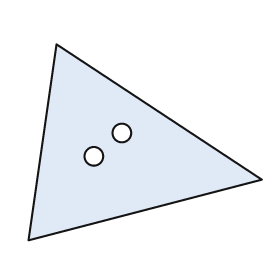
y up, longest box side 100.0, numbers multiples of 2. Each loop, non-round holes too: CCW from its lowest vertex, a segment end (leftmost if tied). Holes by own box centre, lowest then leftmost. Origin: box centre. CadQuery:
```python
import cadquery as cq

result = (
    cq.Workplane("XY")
    .moveTo(-50.0, -42.0)
    .lineTo(50.0, -16.0)
    .lineTo(-38.0, 42.0)
    .close()
    .moveTo(-22.0, -6.0)
    .circle(4.0)
    .moveTo(-10.0, 4.0)
    .circle(4.0)
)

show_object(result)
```